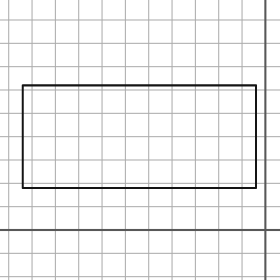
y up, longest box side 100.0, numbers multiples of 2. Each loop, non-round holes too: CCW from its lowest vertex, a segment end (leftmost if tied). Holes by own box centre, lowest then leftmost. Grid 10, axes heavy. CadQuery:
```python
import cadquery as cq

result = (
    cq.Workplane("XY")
    .moveTo(-104.0, 18.0)
    .lineTo(-4.0, 18.0)
    .lineTo(-4.0, 62.0)
    .lineTo(-104.0, 62.0)
    .close()
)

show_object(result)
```